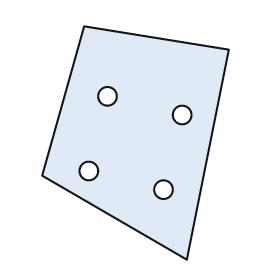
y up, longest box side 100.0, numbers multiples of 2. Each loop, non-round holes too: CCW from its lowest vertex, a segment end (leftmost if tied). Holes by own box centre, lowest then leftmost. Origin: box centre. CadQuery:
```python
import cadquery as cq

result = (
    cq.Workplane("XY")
    .moveTo(22.0, -50.0)
    .lineTo(40.0, 40.0)
    .lineTo(-22.0, 50.0)
    .lineTo(-40.0, -14.0)
    .close()
    .moveTo(12.0, -20.0)
    .circle(4.0)
    .moveTo(-20.0, -12.0)
    .circle(4.0)
    .moveTo(20.0, 12.0)
    .circle(4.0)
    .moveTo(-12.0, 20.0)
    .circle(4.0)
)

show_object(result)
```